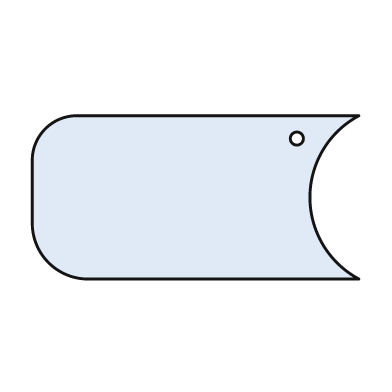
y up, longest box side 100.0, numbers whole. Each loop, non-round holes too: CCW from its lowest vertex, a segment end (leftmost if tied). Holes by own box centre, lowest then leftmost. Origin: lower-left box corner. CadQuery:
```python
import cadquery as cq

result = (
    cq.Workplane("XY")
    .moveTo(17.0, 0.0)
    .lineTo(100.0, 0.0)
    .threePointArc((85.0, 25.0), (100.0, 50.0))
    .lineTo(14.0, 50.0)
    .threePointArc((4.0, 46.0), (0.0, 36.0))
    .lineTo(0.0, 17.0)
    .threePointArc((5.0, 5.0), (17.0, 0.0))
    .close()
    .moveTo(81.0, 43.0)
    .circle(2.0)
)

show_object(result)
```